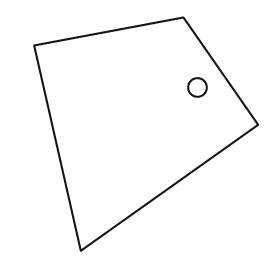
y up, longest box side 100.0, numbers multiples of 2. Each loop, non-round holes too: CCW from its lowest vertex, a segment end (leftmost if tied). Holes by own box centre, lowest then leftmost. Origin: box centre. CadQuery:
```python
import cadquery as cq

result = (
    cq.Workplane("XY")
    .moveTo(-28.0, -50.0)
    .lineTo(48.0, 4.0)
    .lineTo(16.0, 50.0)
    .lineTo(-48.0, 38.0)
    .close()
    .moveTo(22.0, 20.0)
    .circle(4.0)
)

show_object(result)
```